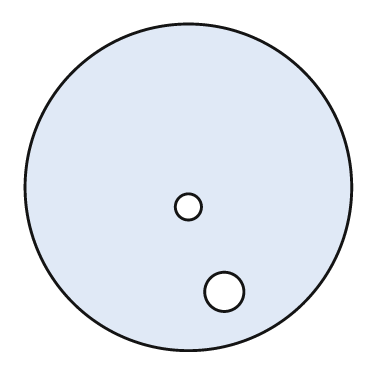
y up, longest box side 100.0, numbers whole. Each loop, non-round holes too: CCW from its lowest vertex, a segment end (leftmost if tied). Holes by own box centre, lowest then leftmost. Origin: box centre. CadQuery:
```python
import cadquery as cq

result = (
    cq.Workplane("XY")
    .moveTo(0.0, 0.0)
    .circle(50.0)
    .moveTo(11.0, -32.0)
    .circle(6.0)
    .moveTo(0.0, -6.0)
    .circle(4.0)
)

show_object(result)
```